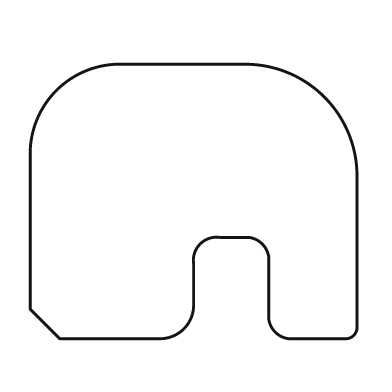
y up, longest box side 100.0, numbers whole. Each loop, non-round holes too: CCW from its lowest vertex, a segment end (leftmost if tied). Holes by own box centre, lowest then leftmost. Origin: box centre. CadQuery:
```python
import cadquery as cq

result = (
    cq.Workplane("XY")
    .moveTo(-41.0, -42.0)
    .lineTo(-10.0, -42.0)
    .threePointArc((-3.0, -39.0), (0.0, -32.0))
    .lineTo(0.0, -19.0)
    .threePointArc((2.0, -13.0), (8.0, -11.0))
    .lineTo(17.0, -11.0)
    .threePointArc((21.0, -13.0), (23.0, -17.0))
    .lineTo(23.0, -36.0)
    .threePointArc((25.0, -40.0), (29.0, -42.0))
    .lineTo(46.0, -42.0)
    .threePointArc((49.0, -41.0), (50.0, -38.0))
    .lineTo(50.0, 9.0)
    .threePointArc((40.0, 32.0), (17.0, 42.0))
    .lineTo(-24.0, 42.0)
    .threePointArc((-42.0, 34.0), (-50.0, 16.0))
    .lineTo(-50.0, -33.0)
    .close()
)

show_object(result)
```